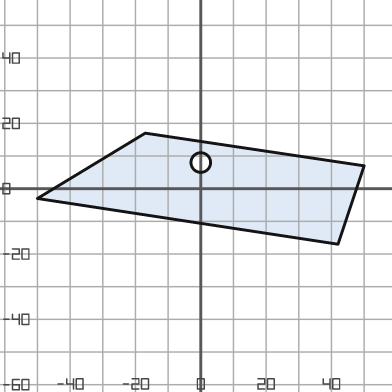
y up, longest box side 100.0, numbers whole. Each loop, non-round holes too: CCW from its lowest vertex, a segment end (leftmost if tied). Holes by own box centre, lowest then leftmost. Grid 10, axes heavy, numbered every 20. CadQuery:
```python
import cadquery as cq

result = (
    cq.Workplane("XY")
    .moveTo(42.0, -17.0)
    .lineTo(50.0, 7.0)
    .lineTo(-17.0, 17.0)
    .lineTo(-50.0, -3.0)
    .close()
    .moveTo(0.0, 8.0)
    .circle(3.0)
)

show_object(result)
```